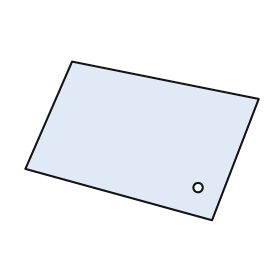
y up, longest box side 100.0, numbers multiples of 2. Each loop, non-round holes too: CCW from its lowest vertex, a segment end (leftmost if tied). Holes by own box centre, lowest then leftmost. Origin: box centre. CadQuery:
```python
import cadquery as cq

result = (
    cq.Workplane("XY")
    .moveTo(30.0, -34.0)
    .lineTo(50.0, 18.0)
    .lineTo(-30.0, 34.0)
    .lineTo(-50.0, -12.0)
    .close()
    .moveTo(24.0, -20.0)
    .circle(2.0)
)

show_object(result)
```